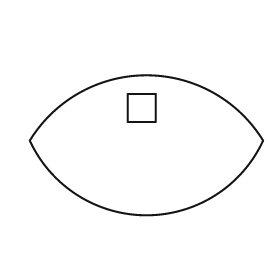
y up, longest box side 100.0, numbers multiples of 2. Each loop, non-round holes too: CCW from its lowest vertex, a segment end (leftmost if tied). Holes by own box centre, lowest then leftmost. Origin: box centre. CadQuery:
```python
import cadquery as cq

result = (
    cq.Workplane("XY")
    .moveTo(-50.0, 2.0)
    .threePointArc((0.0, -30.0), (50.0, 2.0))
    .threePointArc((0.0, 30.0), (-50.0, 2.0))
    .close()
    .moveTo(-8.0, 10.0)
    .lineTo(4.0, 10.0)
    .lineTo(4.0, 22.0)
    .lineTo(-8.0, 22.0)
    .close()
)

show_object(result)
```